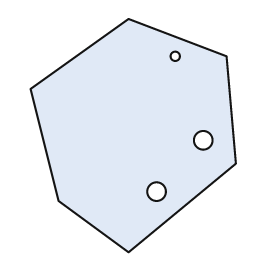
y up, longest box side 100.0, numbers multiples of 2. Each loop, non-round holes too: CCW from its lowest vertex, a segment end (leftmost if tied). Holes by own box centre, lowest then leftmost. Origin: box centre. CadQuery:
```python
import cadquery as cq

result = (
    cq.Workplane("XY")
    .moveTo(-2.0, -50.0)
    .lineTo(44.0, -12.0)
    .lineTo(40.0, 34.0)
    .lineTo(-2.0, 50.0)
    .lineTo(-44.0, 20.0)
    .lineTo(-32.0, -28.0)
    .close()
    .moveTo(10.0, -24.0)
    .circle(4.0)
    .moveTo(30.0, -2.0)
    .circle(4.0)
    .moveTo(18.0, 34.0)
    .circle(2.0)
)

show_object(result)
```